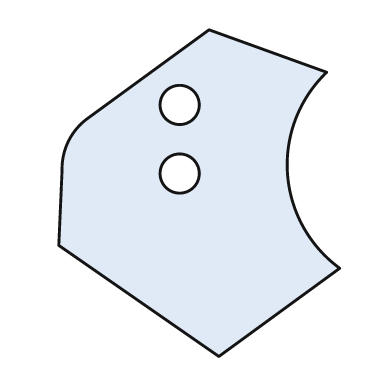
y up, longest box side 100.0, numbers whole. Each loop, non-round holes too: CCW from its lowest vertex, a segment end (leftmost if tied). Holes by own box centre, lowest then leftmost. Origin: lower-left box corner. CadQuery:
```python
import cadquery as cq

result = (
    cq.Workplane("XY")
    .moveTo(49.0, 0.0)
    .lineTo(86.0, 27.0)
    .threePointArc((70.0, 56.0), (82.0, 87.0))
    .lineTo(46.0, 100.0)
    .lineTo(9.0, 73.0)
    .threePointArc((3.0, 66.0), (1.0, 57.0))
    .lineTo(0.0, 34.0)
    .close()
    .moveTo(37.0, 56.0)
    .circle(6.0)
    .moveTo(37.0, 77.0)
    .circle(6.0)
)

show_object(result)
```